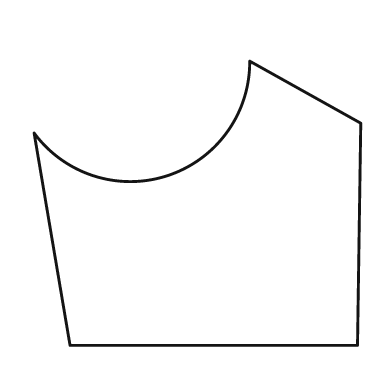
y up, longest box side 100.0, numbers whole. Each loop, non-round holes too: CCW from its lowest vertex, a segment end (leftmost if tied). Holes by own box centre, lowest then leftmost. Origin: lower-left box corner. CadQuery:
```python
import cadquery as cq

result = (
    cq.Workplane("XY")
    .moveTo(11.0, 0.0)
    .lineTo(99.0, 0.0)
    .lineTo(100.0, 68.0)
    .lineTo(66.0, 87.0)
    .threePointArc((41.0, 52.0), (0.0, 65.0))
    .close()
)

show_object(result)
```